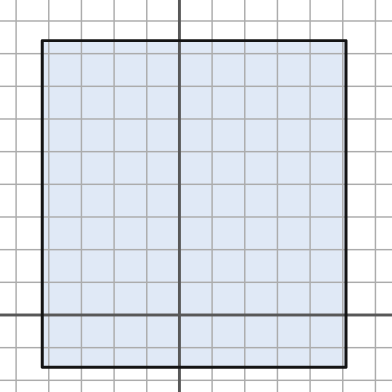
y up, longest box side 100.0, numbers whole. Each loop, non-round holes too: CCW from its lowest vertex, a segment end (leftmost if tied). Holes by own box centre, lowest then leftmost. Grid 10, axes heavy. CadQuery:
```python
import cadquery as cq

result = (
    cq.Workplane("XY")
    .moveTo(-42.0, -16.0)
    .lineTo(51.0, -16.0)
    .lineTo(51.0, 84.0)
    .lineTo(-42.0, 84.0)
    .close()
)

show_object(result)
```